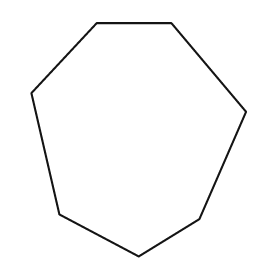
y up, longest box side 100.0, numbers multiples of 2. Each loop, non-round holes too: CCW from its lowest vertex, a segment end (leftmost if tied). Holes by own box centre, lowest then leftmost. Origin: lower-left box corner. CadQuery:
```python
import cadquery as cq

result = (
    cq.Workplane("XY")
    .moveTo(46.0, 0.0)
    .lineTo(72.0, 16.0)
    .lineTo(92.0, 62.0)
    .lineTo(60.0, 100.0)
    .lineTo(28.0, 100.0)
    .lineTo(0.0, 70.0)
    .lineTo(12.0, 18.0)
    .close()
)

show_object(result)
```